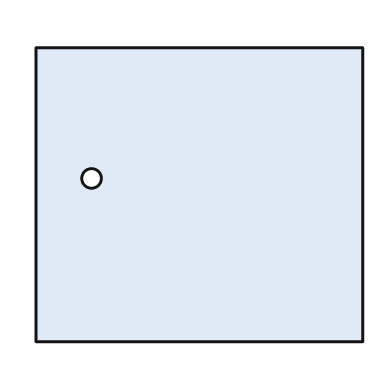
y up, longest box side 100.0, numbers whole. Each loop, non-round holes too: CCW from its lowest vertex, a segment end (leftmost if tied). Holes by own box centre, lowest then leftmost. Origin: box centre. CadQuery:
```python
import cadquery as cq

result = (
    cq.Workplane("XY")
    .moveTo(-50.0, -45.0)
    .lineTo(50.0, -45.0)
    .lineTo(50.0, 45.0)
    .lineTo(-50.0, 45.0)
    .close()
    .moveTo(-33.0, 5.0)
    .circle(3.0)
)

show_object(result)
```